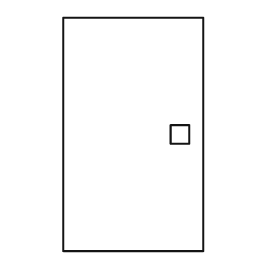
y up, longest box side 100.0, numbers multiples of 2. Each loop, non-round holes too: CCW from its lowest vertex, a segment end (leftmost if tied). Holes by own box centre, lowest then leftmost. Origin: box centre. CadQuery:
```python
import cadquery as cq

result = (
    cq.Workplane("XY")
    .moveTo(-30.0, -50.0)
    .lineTo(30.0, -50.0)
    .lineTo(30.0, 50.0)
    .lineTo(-30.0, 50.0)
    .close()
    .moveTo(16.0, -4.0)
    .lineTo(24.0, -4.0)
    .lineTo(24.0, 4.0)
    .lineTo(16.0, 4.0)
    .close()
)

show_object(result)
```